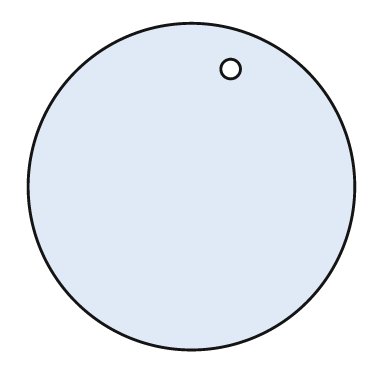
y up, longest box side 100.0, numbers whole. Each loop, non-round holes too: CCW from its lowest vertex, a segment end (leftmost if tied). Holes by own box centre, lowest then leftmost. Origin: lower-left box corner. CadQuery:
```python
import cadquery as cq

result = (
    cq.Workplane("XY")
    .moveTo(50.0, 50.0)
    .circle(50.0)
    .moveTo(62.0, 86.0)
    .circle(3.0)
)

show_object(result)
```